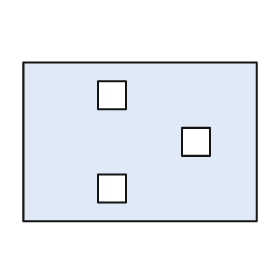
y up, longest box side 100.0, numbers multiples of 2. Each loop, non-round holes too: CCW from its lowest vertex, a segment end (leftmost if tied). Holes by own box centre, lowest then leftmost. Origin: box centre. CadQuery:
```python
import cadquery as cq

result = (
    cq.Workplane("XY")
    .moveTo(-50.0, -34.0)
    .lineTo(50.0, -34.0)
    .lineTo(50.0, 34.0)
    .lineTo(-50.0, 34.0)
    .close()
    .moveTo(-18.0, -26.0)
    .lineTo(-6.0, -26.0)
    .lineTo(-6.0, -14.0)
    .lineTo(-18.0, -14.0)
    .close()
    .moveTo(18.0, -6.0)
    .lineTo(30.0, -6.0)
    .lineTo(30.0, 6.0)
    .lineTo(18.0, 6.0)
    .close()
    .moveTo(-18.0, 14.0)
    .lineTo(-6.0, 14.0)
    .lineTo(-6.0, 26.0)
    .lineTo(-18.0, 26.0)
    .close()
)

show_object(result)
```